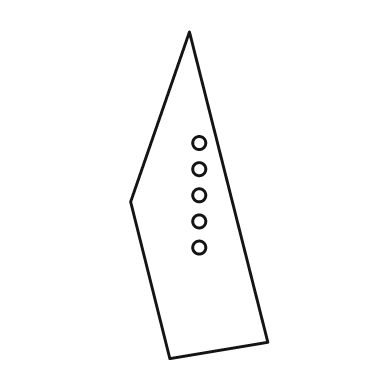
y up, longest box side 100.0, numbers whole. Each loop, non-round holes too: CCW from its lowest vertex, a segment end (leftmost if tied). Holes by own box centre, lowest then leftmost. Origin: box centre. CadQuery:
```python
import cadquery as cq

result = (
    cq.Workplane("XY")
    .moveTo(-9.0, -50.0)
    .lineTo(21.0, -45.0)
    .lineTo(-3.0, 50.0)
    .lineTo(-21.0, -2.0)
    .close()
    .moveTo(0.0, -16.0)
    .circle(2.0)
    .moveTo(0.0, -8.0)
    .circle(2.0)
    .moveTo(0.0, 0.0)
    .circle(2.0)
    .moveTo(0.0, 8.0)
    .circle(2.0)
    .moveTo(0.0, 16.0)
    .circle(2.0)
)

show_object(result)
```